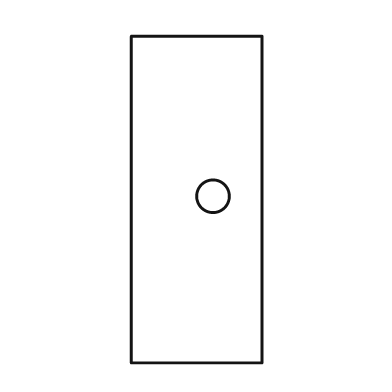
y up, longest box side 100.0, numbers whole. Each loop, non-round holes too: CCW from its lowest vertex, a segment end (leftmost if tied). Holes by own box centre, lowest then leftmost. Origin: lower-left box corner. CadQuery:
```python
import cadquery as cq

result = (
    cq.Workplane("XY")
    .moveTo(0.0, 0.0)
    .lineTo(40.0, 0.0)
    .lineTo(40.0, 100.0)
    .lineTo(0.0, 100.0)
    .close()
    .moveTo(25.0, 51.0)
    .circle(5.0)
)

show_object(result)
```